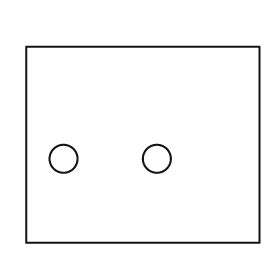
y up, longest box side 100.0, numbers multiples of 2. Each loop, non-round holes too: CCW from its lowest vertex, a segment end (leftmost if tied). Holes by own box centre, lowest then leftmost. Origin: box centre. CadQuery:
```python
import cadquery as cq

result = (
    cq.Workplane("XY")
    .moveTo(-50.0, -42.0)
    .lineTo(50.0, -42.0)
    .lineTo(50.0, 42.0)
    .lineTo(-50.0, 42.0)
    .close()
    .moveTo(-34.0, -6.0)
    .circle(6.0)
    .moveTo(6.0, -6.0)
    .circle(6.0)
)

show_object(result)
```